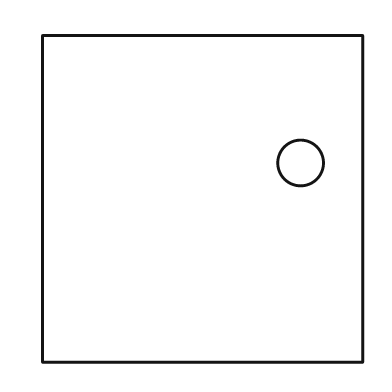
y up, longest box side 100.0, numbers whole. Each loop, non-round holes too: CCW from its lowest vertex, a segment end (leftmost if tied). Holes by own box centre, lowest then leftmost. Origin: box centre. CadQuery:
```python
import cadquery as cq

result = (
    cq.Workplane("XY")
    .moveTo(-49.0, -50.0)
    .lineTo(49.0, -50.0)
    .lineTo(49.0, 50.0)
    .lineTo(-49.0, 50.0)
    .close()
    .moveTo(30.0, 11.0)
    .circle(7.0)
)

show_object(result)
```